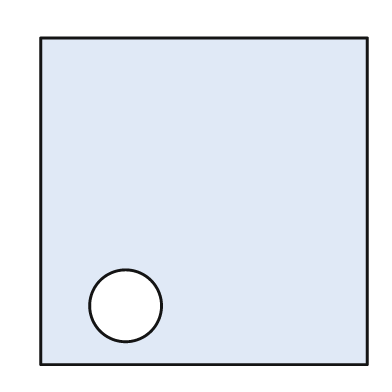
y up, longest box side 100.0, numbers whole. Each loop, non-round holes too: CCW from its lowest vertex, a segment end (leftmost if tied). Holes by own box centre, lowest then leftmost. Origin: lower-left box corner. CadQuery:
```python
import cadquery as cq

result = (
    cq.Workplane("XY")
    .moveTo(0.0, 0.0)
    .lineTo(100.0, 0.0)
    .lineTo(100.0, 100.0)
    .lineTo(0.0, 100.0)
    .close()
    .moveTo(26.0, 18.0)
    .circle(11.0)
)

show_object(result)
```